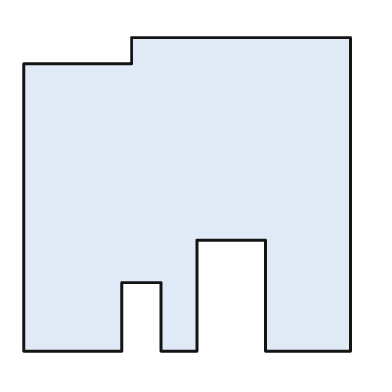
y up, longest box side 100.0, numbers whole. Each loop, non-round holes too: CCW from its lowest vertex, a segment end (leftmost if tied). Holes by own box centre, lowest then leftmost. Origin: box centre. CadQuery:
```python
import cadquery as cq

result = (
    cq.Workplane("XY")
    .moveTo(-50.0, -48.0)
    .lineTo(-20.0, -48.0)
    .lineTo(-20.0, -27.0)
    .lineTo(-8.0, -27.0)
    .lineTo(-8.0, -48.0)
    .lineTo(3.0, -48.0)
    .lineTo(3.0, -14.0)
    .lineTo(24.0, -14.0)
    .lineTo(24.0, -48.0)
    .lineTo(50.0, -48.0)
    .lineTo(50.0, 48.0)
    .lineTo(-17.0, 48.0)
    .lineTo(-17.0, 40.0)
    .lineTo(-50.0, 40.0)
    .close()
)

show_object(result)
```